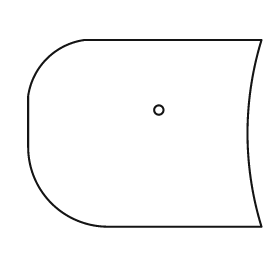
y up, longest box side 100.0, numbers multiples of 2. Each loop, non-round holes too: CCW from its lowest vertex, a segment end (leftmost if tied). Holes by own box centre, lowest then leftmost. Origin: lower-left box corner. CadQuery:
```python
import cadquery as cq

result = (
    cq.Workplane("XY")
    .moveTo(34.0, 0.0)
    .lineTo(100.0, 0.0)
    .threePointArc((94.0, 40.0), (100.0, 80.0))
    .lineTo(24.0, 80.0)
    .threePointArc((8.0, 72.0), (0.0, 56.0))
    .lineTo(0.0, 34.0)
    .threePointArc((10.0, 10.0), (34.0, 0.0))
    .close()
    .moveTo(56.0, 50.0)
    .circle(2.0)
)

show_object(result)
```